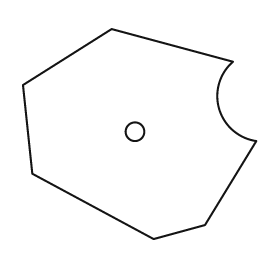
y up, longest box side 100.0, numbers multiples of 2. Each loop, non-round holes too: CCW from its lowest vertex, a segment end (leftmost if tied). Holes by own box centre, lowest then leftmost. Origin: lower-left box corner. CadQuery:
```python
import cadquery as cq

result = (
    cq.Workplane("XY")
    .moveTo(56.0, 0.0)
    .lineTo(78.0, 6.0)
    .lineTo(100.0, 42.0)
    .threePointArc((84.0, 56.0), (90.0, 76.0))
    .lineTo(38.0, 90.0)
    .lineTo(0.0, 66.0)
    .lineTo(4.0, 28.0)
    .close()
    .moveTo(48.0, 46.0)
    .circle(4.0)
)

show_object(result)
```